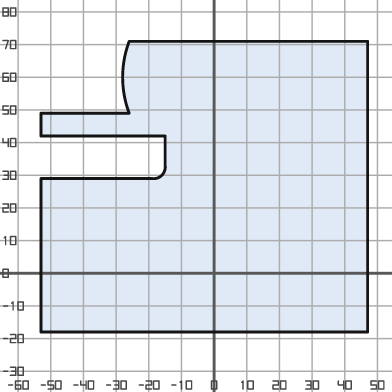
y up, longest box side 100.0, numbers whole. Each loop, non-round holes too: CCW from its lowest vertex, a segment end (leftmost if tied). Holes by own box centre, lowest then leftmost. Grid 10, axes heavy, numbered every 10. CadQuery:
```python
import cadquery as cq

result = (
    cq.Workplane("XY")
    .moveTo(-53.0, -18.0)
    .lineTo(47.0, -18.0)
    .lineTo(47.0, 71.0)
    .lineTo(-26.0, 71.0)
    .threePointArc((-28.0, 60.0), (-26.0, 49.0))
    .lineTo(-53.0, 49.0)
    .lineTo(-53.0, 42.0)
    .lineTo(-15.0, 42.0)
    .lineTo(-15.0, 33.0)
    .threePointArc((-16.0, 30.0), (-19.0, 29.0))
    .lineTo(-53.0, 29.0)
    .close()
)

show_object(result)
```